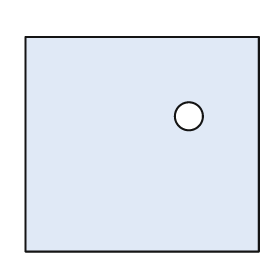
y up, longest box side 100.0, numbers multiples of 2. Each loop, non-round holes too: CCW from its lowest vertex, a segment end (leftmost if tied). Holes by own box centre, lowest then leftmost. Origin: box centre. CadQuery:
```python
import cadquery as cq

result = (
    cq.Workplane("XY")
    .moveTo(-50.0, -46.0)
    .lineTo(50.0, -46.0)
    .lineTo(50.0, 46.0)
    .lineTo(-50.0, 46.0)
    .close()
    .moveTo(20.0, 12.0)
    .circle(6.0)
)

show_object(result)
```